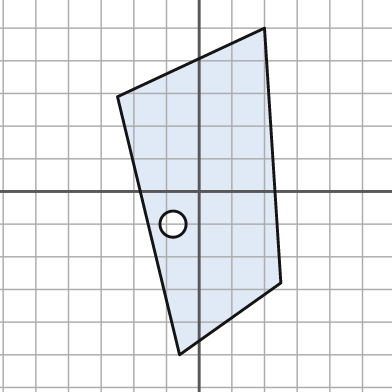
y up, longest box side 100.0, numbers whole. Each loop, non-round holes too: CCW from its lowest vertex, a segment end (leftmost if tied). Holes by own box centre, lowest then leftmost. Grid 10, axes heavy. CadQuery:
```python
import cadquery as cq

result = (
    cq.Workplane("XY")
    .moveTo(-6.0, -50.0)
    .lineTo(25.0, -28.0)
    .lineTo(20.0, 50.0)
    .lineTo(-25.0, 29.0)
    .close()
    .moveTo(-8.0, -10.0)
    .circle(4.0)
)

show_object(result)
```